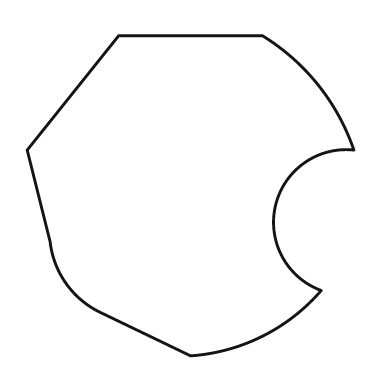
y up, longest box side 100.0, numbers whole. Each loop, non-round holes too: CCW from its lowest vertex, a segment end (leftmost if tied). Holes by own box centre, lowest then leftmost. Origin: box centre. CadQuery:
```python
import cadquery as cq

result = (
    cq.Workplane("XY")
    .moveTo(0.0, -49.0)
    .threePointArc((22.0, -43.0), (40.0, -29.0))
    .threePointArc((26.0, -3.0), (50.0, 14.0))
    .threePointArc((39.0, 34.0), (22.0, 49.0))
    .lineTo(-22.0, 49.0)
    .lineTo(-50.0, 14.0)
    .lineTo(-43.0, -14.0)
    .threePointArc((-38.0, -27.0), (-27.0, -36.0))
    .close()
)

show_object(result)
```